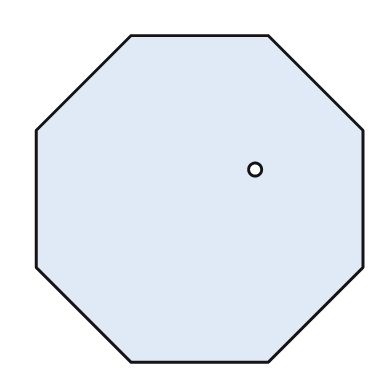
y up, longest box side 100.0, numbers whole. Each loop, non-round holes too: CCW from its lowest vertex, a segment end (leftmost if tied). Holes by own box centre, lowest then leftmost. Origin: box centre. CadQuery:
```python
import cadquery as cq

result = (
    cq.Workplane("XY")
    .moveTo(-21.0, -50.0)
    .lineTo(21.0, -50.0)
    .lineTo(50.0, -21.0)
    .lineTo(50.0, 21.0)
    .lineTo(21.0, 50.0)
    .lineTo(-21.0, 50.0)
    .lineTo(-50.0, 21.0)
    .lineTo(-50.0, -21.0)
    .close()
    .moveTo(17.0, 9.0)
    .circle(2.0)
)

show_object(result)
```